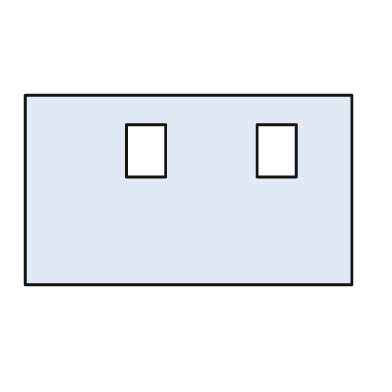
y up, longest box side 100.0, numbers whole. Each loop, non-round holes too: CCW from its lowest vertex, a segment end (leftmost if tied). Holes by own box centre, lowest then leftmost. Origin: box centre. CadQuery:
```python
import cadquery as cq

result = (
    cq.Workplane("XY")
    .moveTo(-50.0, -29.0)
    .lineTo(50.0, -29.0)
    .lineTo(50.0, 29.0)
    .lineTo(-50.0, 29.0)
    .close()
    .moveTo(-19.0, 4.0)
    .lineTo(-7.0, 4.0)
    .lineTo(-7.0, 20.0)
    .lineTo(-19.0, 20.0)
    .close()
    .moveTo(21.0, 4.0)
    .lineTo(33.0, 4.0)
    .lineTo(33.0, 20.0)
    .lineTo(21.0, 20.0)
    .close()
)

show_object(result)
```